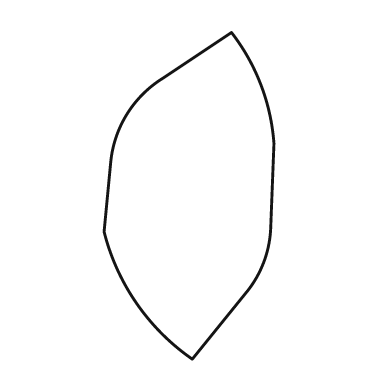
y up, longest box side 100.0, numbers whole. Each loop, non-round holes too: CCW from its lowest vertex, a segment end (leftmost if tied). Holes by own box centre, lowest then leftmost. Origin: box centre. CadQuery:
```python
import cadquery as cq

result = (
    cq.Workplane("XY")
    .moveTo(1.0, -50.0)
    .lineTo(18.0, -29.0)
    .threePointArc((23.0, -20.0), (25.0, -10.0))
    .lineTo(26.0, 16.0)
    .threePointArc((22.0, 34.0), (13.0, 50.0))
    .lineTo(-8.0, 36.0)
    .threePointArc((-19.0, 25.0), (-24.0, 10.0))
    .lineTo(-26.0, -11.0)
    .threePointArc((-16.0, -33.0), (1.0, -50.0))
    .close()
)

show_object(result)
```